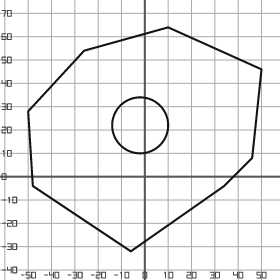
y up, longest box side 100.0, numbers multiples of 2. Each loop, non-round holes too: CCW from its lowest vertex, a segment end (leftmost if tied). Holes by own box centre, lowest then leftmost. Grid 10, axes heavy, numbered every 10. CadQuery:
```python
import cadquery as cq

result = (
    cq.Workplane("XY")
    .moveTo(-6.0, -32.0)
    .lineTo(34.0, -4.0)
    .lineTo(46.0, 8.0)
    .lineTo(50.0, 46.0)
    .lineTo(10.0, 64.0)
    .lineTo(-26.0, 54.0)
    .lineTo(-50.0, 28.0)
    .lineTo(-48.0, -4.0)
    .close()
    .moveTo(-2.0, 22.0)
    .circle(12.0)
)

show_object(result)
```